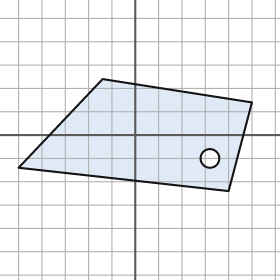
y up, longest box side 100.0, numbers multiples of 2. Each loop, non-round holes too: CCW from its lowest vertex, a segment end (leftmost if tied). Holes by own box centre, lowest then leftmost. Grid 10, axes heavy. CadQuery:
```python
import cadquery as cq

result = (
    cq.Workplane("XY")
    .moveTo(40.0, -24.0)
    .lineTo(50.0, 14.0)
    .lineTo(-14.0, 24.0)
    .lineTo(-50.0, -14.0)
    .close()
    .moveTo(32.0, -10.0)
    .circle(4.0)
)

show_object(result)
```